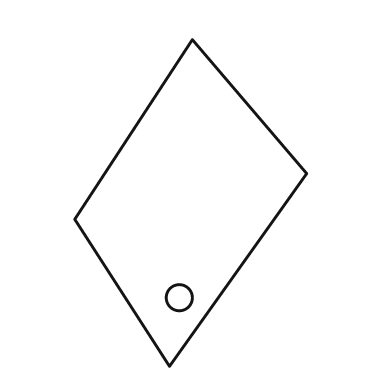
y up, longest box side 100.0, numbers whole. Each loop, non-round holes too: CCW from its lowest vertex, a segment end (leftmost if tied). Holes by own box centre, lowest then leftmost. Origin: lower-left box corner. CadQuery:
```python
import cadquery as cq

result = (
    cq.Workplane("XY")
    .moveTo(29.0, 0.0)
    .lineTo(71.0, 59.0)
    .lineTo(36.0, 100.0)
    .lineTo(0.0, 45.0)
    .close()
    .moveTo(32.0, 21.0)
    .circle(4.0)
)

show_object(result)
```